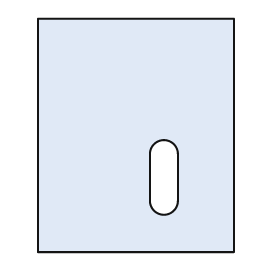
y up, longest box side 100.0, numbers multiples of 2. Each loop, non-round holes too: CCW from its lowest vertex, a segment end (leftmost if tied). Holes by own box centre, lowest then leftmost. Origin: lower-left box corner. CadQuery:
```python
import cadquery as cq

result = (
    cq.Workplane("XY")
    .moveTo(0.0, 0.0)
    .lineTo(84.0, 0.0)
    .lineTo(84.0, 100.0)
    .lineTo(0.0, 100.0)
    .close()
    .moveTo(48.0, 22.0)
    .threePointArc((54.0, 16.0), (60.0, 22.0))
    .lineTo(60.0, 42.0)
    .threePointArc((54.0, 48.0), (48.0, 42.0))
    .close()
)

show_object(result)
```